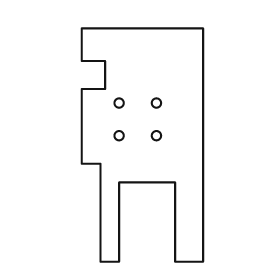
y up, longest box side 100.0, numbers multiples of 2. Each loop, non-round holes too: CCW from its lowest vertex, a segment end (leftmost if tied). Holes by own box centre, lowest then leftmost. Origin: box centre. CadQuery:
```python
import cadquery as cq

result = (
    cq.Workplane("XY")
    .moveTo(-18.0, -50.0)
    .lineTo(-10.0, -50.0)
    .lineTo(-10.0, -16.0)
    .lineTo(14.0, -16.0)
    .lineTo(14.0, -50.0)
    .lineTo(26.0, -50.0)
    .lineTo(26.0, 50.0)
    .lineTo(-26.0, 50.0)
    .lineTo(-26.0, 36.0)
    .lineTo(-16.0, 36.0)
    .lineTo(-16.0, 24.0)
    .lineTo(-26.0, 24.0)
    .lineTo(-26.0, -8.0)
    .lineTo(-18.0, -8.0)
    .close()
    .moveTo(-10.0, 4.0)
    .circle(2.0)
    .moveTo(6.0, 4.0)
    .circle(2.0)
    .moveTo(-10.0, 18.0)
    .circle(2.0)
    .moveTo(6.0, 18.0)
    .circle(2.0)
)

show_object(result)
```